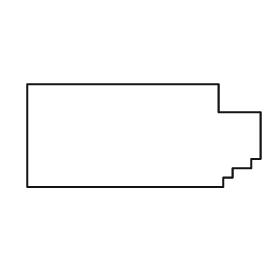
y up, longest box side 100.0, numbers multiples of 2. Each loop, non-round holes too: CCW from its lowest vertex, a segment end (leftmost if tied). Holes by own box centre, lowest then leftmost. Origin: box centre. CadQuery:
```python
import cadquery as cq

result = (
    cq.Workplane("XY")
    .moveTo(-50.0, -22.0)
    .lineTo(34.0, -22.0)
    .lineTo(34.0, -18.0)
    .lineTo(38.0, -18.0)
    .lineTo(38.0, -14.0)
    .lineTo(46.0, -14.0)
    .lineTo(46.0, -10.0)
    .lineTo(50.0, -10.0)
    .lineTo(50.0, 10.0)
    .lineTo(32.0, 10.0)
    .lineTo(32.0, 22.0)
    .lineTo(-50.0, 22.0)
    .close()
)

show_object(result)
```